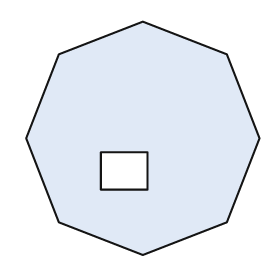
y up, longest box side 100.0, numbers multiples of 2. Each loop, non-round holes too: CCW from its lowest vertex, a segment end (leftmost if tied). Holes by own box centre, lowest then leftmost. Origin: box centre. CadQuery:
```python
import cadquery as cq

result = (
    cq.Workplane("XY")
    .moveTo(0.0, -50.0)
    .lineTo(36.0, -36.0)
    .lineTo(50.0, 0.0)
    .lineTo(36.0, 36.0)
    .lineTo(0.0, 50.0)
    .lineTo(-36.0, 36.0)
    .lineTo(-50.0, 0.0)
    .lineTo(-36.0, -36.0)
    .close()
    .moveTo(-18.0, -22.0)
    .lineTo(2.0, -22.0)
    .lineTo(2.0, -6.0)
    .lineTo(-18.0, -6.0)
    .close()
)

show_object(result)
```